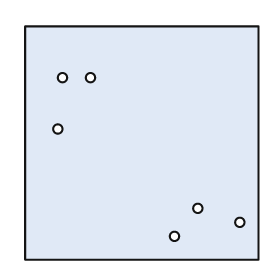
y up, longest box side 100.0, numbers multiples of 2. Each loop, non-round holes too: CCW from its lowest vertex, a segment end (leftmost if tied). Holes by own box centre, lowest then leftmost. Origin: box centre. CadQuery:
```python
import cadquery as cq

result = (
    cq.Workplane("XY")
    .moveTo(-50.0, -50.0)
    .lineTo(50.0, -50.0)
    .lineTo(50.0, 50.0)
    .lineTo(-50.0, 50.0)
    .close()
    .moveTo(14.0, -40.0)
    .circle(2.0)
    .moveTo(42.0, -34.0)
    .circle(2.0)
    .moveTo(24.0, -28.0)
    .circle(2.0)
    .moveTo(-36.0, 6.0)
    .circle(2.0)
    .moveTo(-34.0, 28.0)
    .circle(2.0)
    .moveTo(-22.0, 28.0)
    .circle(2.0)
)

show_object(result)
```